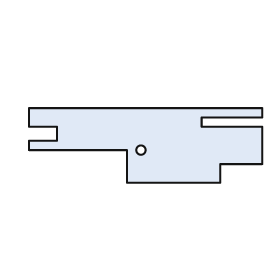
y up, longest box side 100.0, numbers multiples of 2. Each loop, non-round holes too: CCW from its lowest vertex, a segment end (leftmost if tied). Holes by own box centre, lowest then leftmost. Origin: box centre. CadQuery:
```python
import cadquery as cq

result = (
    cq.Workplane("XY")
    .moveTo(-8.0, -16.0)
    .lineTo(32.0, -16.0)
    .lineTo(32.0, -8.0)
    .lineTo(50.0, -8.0)
    .lineTo(50.0, 8.0)
    .lineTo(24.0, 8.0)
    .lineTo(24.0, 12.0)
    .lineTo(50.0, 12.0)
    .lineTo(50.0, 16.0)
    .lineTo(-50.0, 16.0)
    .lineTo(-50.0, 8.0)
    .lineTo(-38.0, 8.0)
    .lineTo(-38.0, 2.0)
    .lineTo(-50.0, 2.0)
    .lineTo(-50.0, -2.0)
    .lineTo(-8.0, -2.0)
    .close()
    .moveTo(-2.0, -2.0)
    .circle(2.0)
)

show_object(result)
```